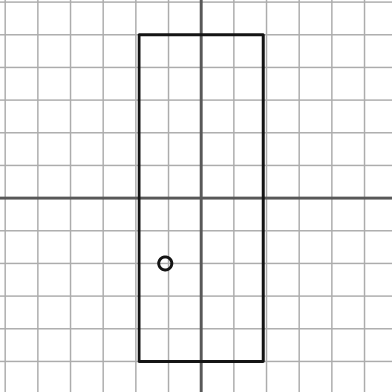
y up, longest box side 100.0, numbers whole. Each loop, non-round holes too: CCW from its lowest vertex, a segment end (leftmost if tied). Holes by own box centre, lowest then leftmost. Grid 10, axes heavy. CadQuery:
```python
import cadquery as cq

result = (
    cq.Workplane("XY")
    .moveTo(-19.0, -50.0)
    .lineTo(19.0, -50.0)
    .lineTo(19.0, 50.0)
    .lineTo(-19.0, 50.0)
    .close()
    .moveTo(-11.0, -20.0)
    .circle(2.0)
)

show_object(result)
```